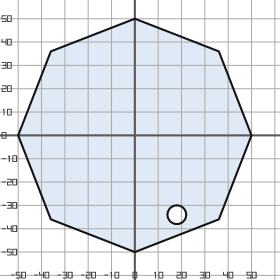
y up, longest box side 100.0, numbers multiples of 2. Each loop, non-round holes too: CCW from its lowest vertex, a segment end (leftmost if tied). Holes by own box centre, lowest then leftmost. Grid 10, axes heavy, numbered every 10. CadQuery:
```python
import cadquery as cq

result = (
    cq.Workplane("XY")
    .moveTo(0.0, -50.0)
    .lineTo(36.0, -36.0)
    .lineTo(50.0, 0.0)
    .lineTo(36.0, 36.0)
    .lineTo(0.0, 50.0)
    .lineTo(-36.0, 36.0)
    .lineTo(-50.0, 0.0)
    .lineTo(-36.0, -36.0)
    .close()
    .moveTo(18.0, -34.0)
    .circle(4.0)
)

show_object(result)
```